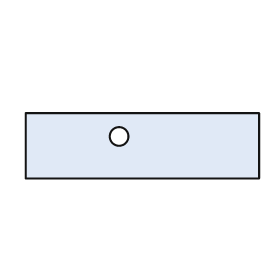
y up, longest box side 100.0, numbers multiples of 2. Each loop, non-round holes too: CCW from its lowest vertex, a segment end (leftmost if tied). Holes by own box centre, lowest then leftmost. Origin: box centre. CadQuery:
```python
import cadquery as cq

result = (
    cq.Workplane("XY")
    .moveTo(-50.0, -14.0)
    .lineTo(50.0, -14.0)
    .lineTo(50.0, 14.0)
    .lineTo(-50.0, 14.0)
    .close()
    .moveTo(-10.0, 4.0)
    .circle(4.0)
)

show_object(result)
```